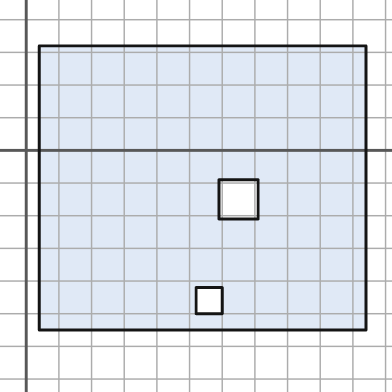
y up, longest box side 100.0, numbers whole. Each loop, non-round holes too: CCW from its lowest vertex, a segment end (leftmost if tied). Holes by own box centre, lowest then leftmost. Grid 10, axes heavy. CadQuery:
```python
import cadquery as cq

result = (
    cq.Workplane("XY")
    .moveTo(4.0, -55.0)
    .lineTo(104.0, -55.0)
    .lineTo(104.0, 32.0)
    .lineTo(4.0, 32.0)
    .close()
    .moveTo(52.0, -50.0)
    .lineTo(60.0, -50.0)
    .lineTo(60.0, -42.0)
    .lineTo(52.0, -42.0)
    .close()
    .moveTo(59.0, -21.0)
    .lineTo(71.0, -21.0)
    .lineTo(71.0, -9.0)
    .lineTo(59.0, -9.0)
    .close()
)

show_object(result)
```